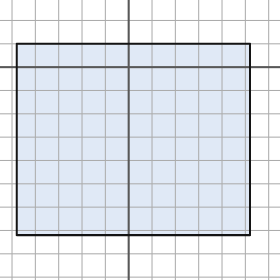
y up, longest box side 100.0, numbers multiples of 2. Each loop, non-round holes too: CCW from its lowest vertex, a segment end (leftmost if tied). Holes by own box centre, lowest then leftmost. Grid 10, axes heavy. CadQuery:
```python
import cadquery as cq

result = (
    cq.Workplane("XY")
    .moveTo(-48.0, -72.0)
    .lineTo(52.0, -72.0)
    .lineTo(52.0, 10.0)
    .lineTo(-48.0, 10.0)
    .close()
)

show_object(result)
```